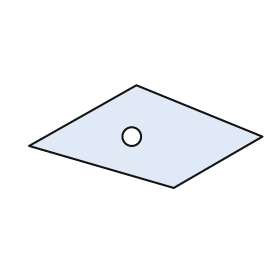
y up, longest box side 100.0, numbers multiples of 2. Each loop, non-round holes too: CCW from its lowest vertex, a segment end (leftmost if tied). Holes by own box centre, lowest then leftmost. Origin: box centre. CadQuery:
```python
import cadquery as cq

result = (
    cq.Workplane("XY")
    .moveTo(12.0, -22.0)
    .lineTo(50.0, 0.0)
    .lineTo(-4.0, 22.0)
    .lineTo(-50.0, -4.0)
    .close()
    .moveTo(-6.0, 0.0)
    .circle(4.0)
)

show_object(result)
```